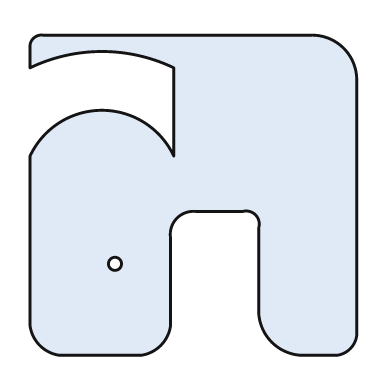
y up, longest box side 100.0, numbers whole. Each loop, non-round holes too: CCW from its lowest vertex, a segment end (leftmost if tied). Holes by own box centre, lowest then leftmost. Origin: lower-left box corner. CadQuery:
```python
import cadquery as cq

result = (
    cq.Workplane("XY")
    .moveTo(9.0, 0.0)
    .lineTo(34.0, 0.0)
    .threePointArc((40.0, 3.0), (43.0, 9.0))
    .lineTo(43.0, 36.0)
    .threePointArc((45.0, 42.0), (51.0, 44.0))
    .lineTo(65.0, 44.0)
    .threePointArc((69.0, 43.0), (70.0, 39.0))
    .lineTo(70.0, 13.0)
    .threePointArc((74.0, 4.0), (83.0, 0.0))
    .lineTo(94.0, 0.0)
    .threePointArc((98.0, 2.0), (100.0, 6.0))
    .lineTo(100.0, 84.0)
    .threePointArc((96.0, 94.0), (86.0, 98.0))
    .lineTo(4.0, 98.0)
    .threePointArc((1.0, 97.0), (0.0, 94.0))
    .lineTo(0.0, 88.0)
    .threePointArc((22.0, 93.0), (44.0, 88.0))
    .lineTo(44.0, 61.0)
    .threePointArc((22.0, 75.0), (0.0, 61.0))
    .lineTo(0.0, 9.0)
    .threePointArc((3.0, 3.0), (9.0, 0.0))
    .close()
    .moveTo(26.0, 28.0)
    .circle(2.0)
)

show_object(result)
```